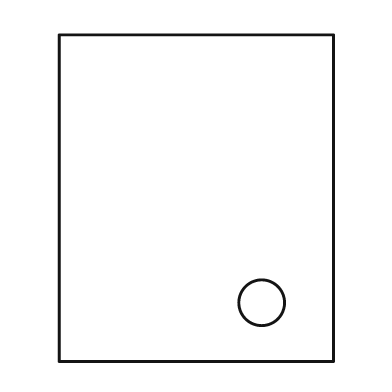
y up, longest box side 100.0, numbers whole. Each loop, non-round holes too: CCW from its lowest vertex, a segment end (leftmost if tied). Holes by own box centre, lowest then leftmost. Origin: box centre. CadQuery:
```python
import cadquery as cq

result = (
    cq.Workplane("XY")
    .moveTo(-42.0, -50.0)
    .lineTo(42.0, -50.0)
    .lineTo(42.0, 50.0)
    .lineTo(-42.0, 50.0)
    .close()
    .moveTo(20.0, -32.0)
    .circle(7.0)
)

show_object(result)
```